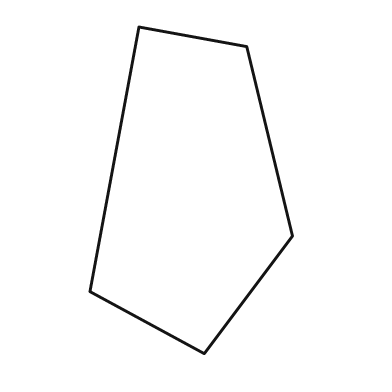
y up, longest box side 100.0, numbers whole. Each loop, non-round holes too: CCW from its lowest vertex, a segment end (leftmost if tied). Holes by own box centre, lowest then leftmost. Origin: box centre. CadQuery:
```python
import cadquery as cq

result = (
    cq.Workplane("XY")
    .moveTo(4.0, -50.0)
    .lineTo(31.0, -14.0)
    .lineTo(17.0, 44.0)
    .lineTo(-16.0, 50.0)
    .lineTo(-31.0, -31.0)
    .close()
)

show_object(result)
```